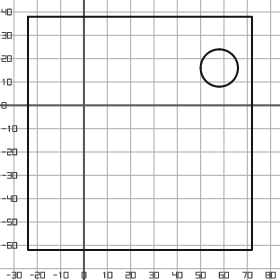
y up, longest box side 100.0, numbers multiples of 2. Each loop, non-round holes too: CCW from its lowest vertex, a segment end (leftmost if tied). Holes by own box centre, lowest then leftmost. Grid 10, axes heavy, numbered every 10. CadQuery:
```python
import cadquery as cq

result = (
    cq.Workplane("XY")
    .moveTo(-24.0, -62.0)
    .lineTo(72.0, -62.0)
    .lineTo(72.0, 38.0)
    .lineTo(-24.0, 38.0)
    .close()
    .moveTo(58.0, 16.0)
    .circle(8.0)
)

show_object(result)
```